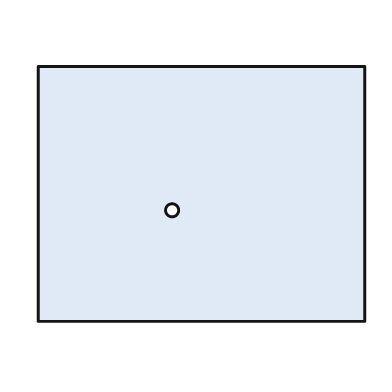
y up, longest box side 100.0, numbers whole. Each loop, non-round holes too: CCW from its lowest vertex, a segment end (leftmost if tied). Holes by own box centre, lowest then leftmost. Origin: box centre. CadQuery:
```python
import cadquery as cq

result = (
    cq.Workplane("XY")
    .moveTo(-50.0, -39.0)
    .lineTo(50.0, -39.0)
    .lineTo(50.0, 39.0)
    .lineTo(-50.0, 39.0)
    .close()
    .moveTo(-9.0, -5.0)
    .circle(2.0)
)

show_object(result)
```